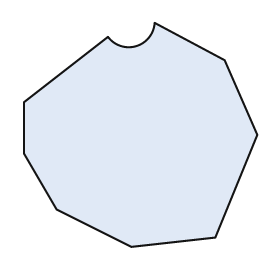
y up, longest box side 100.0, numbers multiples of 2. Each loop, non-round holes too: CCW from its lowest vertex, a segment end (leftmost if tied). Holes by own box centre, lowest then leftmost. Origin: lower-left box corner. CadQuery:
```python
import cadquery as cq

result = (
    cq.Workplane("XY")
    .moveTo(46.0, 0.0)
    .lineTo(82.0, 4.0)
    .lineTo(100.0, 48.0)
    .lineTo(86.0, 80.0)
    .lineTo(56.0, 96.0)
    .threePointArc((48.0, 86.0), (36.0, 90.0))
    .lineTo(0.0, 62.0)
    .lineTo(0.0, 40.0)
    .lineTo(14.0, 16.0)
    .close()
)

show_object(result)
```